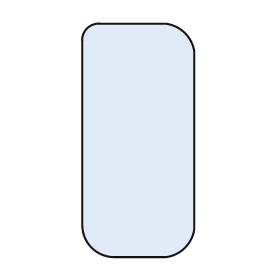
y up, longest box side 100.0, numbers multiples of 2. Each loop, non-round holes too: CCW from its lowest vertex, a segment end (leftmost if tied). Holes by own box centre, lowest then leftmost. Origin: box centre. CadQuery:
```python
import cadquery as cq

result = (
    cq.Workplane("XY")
    .moveTo(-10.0, -50.0)
    .lineTo(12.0, -50.0)
    .threePointArc((20.0, -46.0), (24.0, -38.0))
    .lineTo(24.0, 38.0)
    .threePointArc((20.0, 46.0), (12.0, 50.0))
    .lineTo(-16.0, 50.0)
    .threePointArc((-22.0, 48.0), (-24.0, 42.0))
    .lineTo(-24.0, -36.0)
    .threePointArc((-20.0, -46.0), (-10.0, -50.0))
    .close()
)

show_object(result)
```